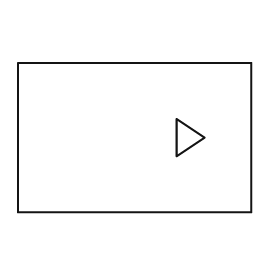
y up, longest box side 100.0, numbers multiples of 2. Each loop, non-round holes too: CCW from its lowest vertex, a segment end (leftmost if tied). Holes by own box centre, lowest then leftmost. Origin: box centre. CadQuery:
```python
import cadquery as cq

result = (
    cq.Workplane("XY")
    .moveTo(-50.0, -32.0)
    .lineTo(50.0, -32.0)
    .lineTo(50.0, 32.0)
    .lineTo(-50.0, 32.0)
    .close()
    .moveTo(18.0, -8.0)
    .lineTo(30.0, 0.0)
    .lineTo(18.0, 8.0)
    .close()
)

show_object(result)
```